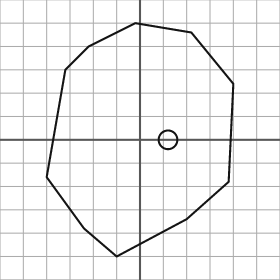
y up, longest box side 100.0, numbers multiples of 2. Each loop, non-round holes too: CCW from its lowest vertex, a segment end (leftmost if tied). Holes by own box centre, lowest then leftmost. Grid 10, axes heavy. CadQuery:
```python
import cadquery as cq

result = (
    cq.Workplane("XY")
    .moveTo(-10.0, -50.0)
    .lineTo(20.0, -34.0)
    .lineTo(38.0, -18.0)
    .lineTo(40.0, 24.0)
    .lineTo(22.0, 46.0)
    .lineTo(-2.0, 50.0)
    .lineTo(-22.0, 40.0)
    .lineTo(-32.0, 30.0)
    .lineTo(-40.0, -16.0)
    .lineTo(-24.0, -38.0)
    .close()
    .moveTo(12.0, 0.0)
    .circle(4.0)
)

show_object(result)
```